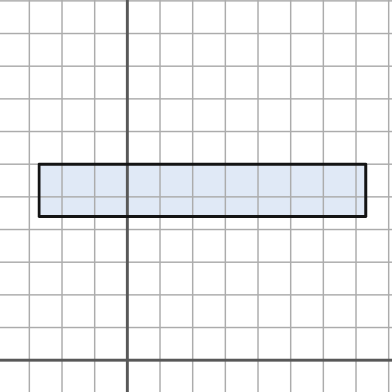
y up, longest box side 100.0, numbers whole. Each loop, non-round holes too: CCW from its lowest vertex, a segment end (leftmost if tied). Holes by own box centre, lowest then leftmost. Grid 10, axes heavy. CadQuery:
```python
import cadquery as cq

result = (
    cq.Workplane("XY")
    .moveTo(-27.0, 44.0)
    .lineTo(73.0, 44.0)
    .lineTo(73.0, 60.0)
    .lineTo(-27.0, 60.0)
    .close()
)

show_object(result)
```